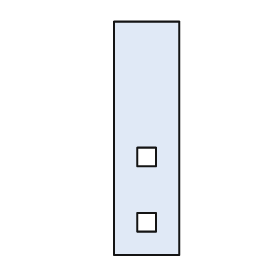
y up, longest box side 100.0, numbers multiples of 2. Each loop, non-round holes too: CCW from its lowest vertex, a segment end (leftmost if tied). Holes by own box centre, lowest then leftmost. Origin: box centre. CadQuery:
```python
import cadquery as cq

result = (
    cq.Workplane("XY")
    .moveTo(-14.0, -50.0)
    .lineTo(14.0, -50.0)
    .lineTo(14.0, 50.0)
    .lineTo(-14.0, 50.0)
    .close()
    .moveTo(-4.0, -40.0)
    .lineTo(4.0, -40.0)
    .lineTo(4.0, -32.0)
    .lineTo(-4.0, -32.0)
    .close()
    .moveTo(-4.0, -12.0)
    .lineTo(4.0, -12.0)
    .lineTo(4.0, -4.0)
    .lineTo(-4.0, -4.0)
    .close()
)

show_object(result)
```